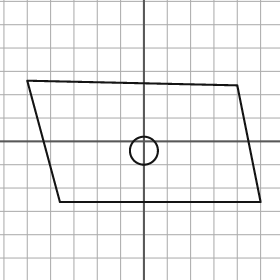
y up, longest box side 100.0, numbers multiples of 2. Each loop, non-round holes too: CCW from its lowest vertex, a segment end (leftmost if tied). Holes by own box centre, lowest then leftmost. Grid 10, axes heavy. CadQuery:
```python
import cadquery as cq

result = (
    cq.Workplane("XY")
    .moveTo(-36.0, -26.0)
    .lineTo(50.0, -26.0)
    .lineTo(40.0, 24.0)
    .lineTo(-50.0, 26.0)
    .close()
    .moveTo(0.0, -4.0)
    .circle(6.0)
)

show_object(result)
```